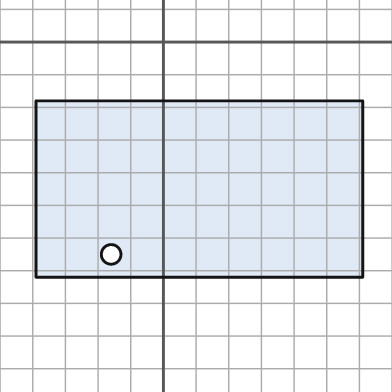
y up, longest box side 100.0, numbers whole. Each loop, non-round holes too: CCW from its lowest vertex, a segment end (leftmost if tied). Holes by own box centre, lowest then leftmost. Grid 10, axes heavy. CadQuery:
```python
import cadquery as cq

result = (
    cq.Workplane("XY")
    .moveTo(-39.0, -72.0)
    .lineTo(61.0, -72.0)
    .lineTo(61.0, -18.0)
    .lineTo(-39.0, -18.0)
    .close()
    .moveTo(-16.0, -65.0)
    .circle(3.0)
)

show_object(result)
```